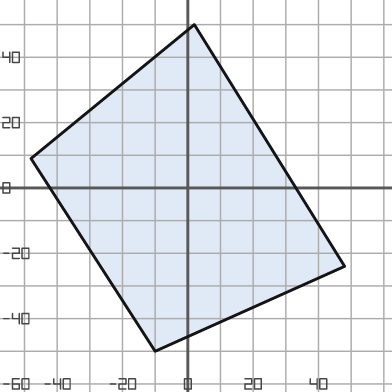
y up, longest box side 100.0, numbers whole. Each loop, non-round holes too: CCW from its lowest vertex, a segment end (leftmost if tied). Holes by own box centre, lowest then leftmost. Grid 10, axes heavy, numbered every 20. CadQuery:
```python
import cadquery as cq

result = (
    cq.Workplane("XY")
    .moveTo(-10.0, -50.0)
    .lineTo(48.0, -24.0)
    .lineTo(2.0, 50.0)
    .lineTo(-48.0, 9.0)
    .close()
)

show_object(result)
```